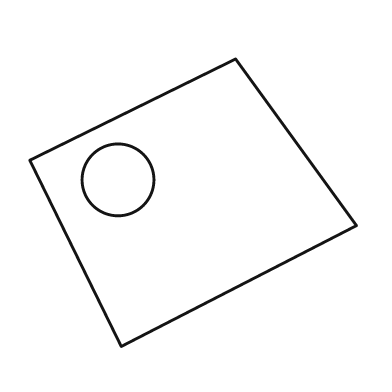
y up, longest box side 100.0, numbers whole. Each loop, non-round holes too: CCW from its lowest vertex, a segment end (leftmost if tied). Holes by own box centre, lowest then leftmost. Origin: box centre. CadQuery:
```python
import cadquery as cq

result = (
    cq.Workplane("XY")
    .moveTo(-22.0, -44.0)
    .lineTo(50.0, -7.0)
    .lineTo(13.0, 44.0)
    .lineTo(-50.0, 13.0)
    .close()
    .moveTo(-23.0, 7.0)
    .circle(11.0)
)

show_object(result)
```